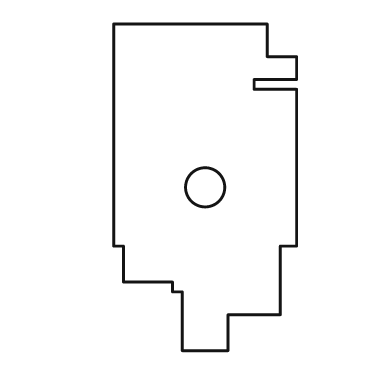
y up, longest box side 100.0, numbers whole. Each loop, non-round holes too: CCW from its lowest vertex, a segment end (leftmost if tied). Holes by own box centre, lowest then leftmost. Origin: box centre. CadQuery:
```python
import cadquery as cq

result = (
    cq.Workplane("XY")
    .moveTo(-7.0, -50.0)
    .lineTo(7.0, -50.0)
    .lineTo(7.0, -39.0)
    .lineTo(23.0, -39.0)
    .lineTo(23.0, -18.0)
    .lineTo(28.0, -18.0)
    .lineTo(28.0, 30.0)
    .lineTo(15.0, 30.0)
    .lineTo(15.0, 33.0)
    .lineTo(28.0, 33.0)
    .lineTo(28.0, 40.0)
    .lineTo(19.0, 40.0)
    .lineTo(19.0, 50.0)
    .lineTo(-28.0, 50.0)
    .lineTo(-28.0, -18.0)
    .lineTo(-25.0, -18.0)
    .lineTo(-25.0, -29.0)
    .lineTo(-10.0, -29.0)
    .lineTo(-10.0, -32.0)
    .lineTo(-7.0, -32.0)
    .close()
    .moveTo(0.0, 0.0)
    .circle(6.0)
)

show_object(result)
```